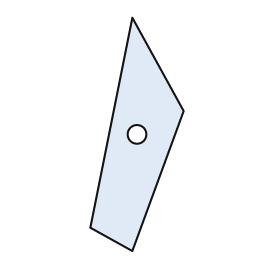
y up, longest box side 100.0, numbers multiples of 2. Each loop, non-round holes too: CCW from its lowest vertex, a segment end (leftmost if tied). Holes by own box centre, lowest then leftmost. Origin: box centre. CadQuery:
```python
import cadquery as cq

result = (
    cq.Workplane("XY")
    .moveTo(-2.0, -50.0)
    .lineTo(20.0, 10.0)
    .lineTo(-2.0, 50.0)
    .lineTo(-20.0, -40.0)
    .close()
    .moveTo(0.0, 0.0)
    .circle(4.0)
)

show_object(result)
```